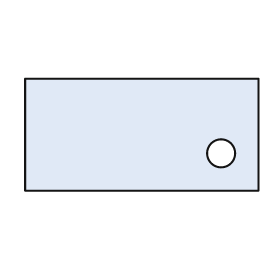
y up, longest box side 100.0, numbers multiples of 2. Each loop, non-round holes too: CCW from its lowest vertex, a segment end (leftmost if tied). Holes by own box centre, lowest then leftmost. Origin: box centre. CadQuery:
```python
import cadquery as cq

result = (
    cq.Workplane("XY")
    .moveTo(-50.0, -24.0)
    .lineTo(50.0, -24.0)
    .lineTo(50.0, 24.0)
    .lineTo(-50.0, 24.0)
    .close()
    .moveTo(34.0, -8.0)
    .circle(6.0)
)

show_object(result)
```